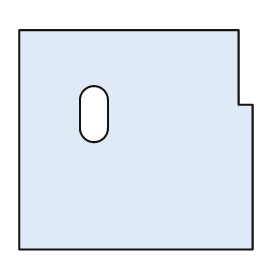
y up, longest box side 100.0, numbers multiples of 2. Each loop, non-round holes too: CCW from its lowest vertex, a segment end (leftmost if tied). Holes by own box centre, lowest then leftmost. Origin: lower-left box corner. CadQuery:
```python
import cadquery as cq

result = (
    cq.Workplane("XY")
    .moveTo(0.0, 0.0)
    .lineTo(100.0, 0.0)
    .lineTo(100.0, 62.0)
    .lineTo(94.0, 62.0)
    .lineTo(94.0, 94.0)
    .lineTo(0.0, 94.0)
    .close()
    .moveTo(26.0, 52.0)
    .threePointArc((32.0, 46.0), (38.0, 52.0))
    .lineTo(38.0, 64.0)
    .threePointArc((32.0, 70.0), (26.0, 64.0))
    .close()
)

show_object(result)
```